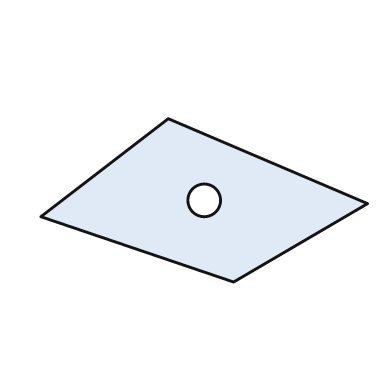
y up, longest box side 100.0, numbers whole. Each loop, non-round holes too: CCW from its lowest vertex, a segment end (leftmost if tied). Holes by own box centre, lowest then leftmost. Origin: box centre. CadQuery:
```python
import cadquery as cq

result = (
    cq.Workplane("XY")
    .moveTo(9.0, -25.0)
    .lineTo(50.0, -1.0)
    .lineTo(-11.0, 25.0)
    .lineTo(-50.0, -5.0)
    .close()
    .moveTo(0.0, 0.0)
    .circle(5.0)
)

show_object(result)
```